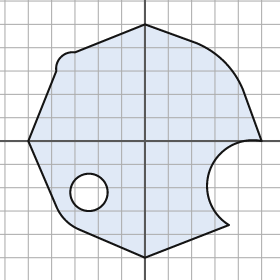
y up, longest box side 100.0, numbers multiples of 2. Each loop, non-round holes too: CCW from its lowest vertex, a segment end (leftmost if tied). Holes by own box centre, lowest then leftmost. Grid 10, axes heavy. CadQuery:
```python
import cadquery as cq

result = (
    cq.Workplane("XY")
    .moveTo(0.0, -50.0)
    .lineTo(36.0, -36.0)
    .threePointArc((28.0, -12.0), (50.0, 0.0))
    .lineTo(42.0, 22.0)
    .threePointArc((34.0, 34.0), (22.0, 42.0))
    .lineTo(0.0, 50.0)
    .lineTo(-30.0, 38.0)
    .threePointArc((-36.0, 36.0), (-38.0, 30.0))
    .lineTo(-50.0, 0.0)
    .lineTo(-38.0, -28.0)
    .threePointArc((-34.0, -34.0), (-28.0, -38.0))
    .close()
    .moveTo(-24.0, -22.0)
    .circle(8.0)
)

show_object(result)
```